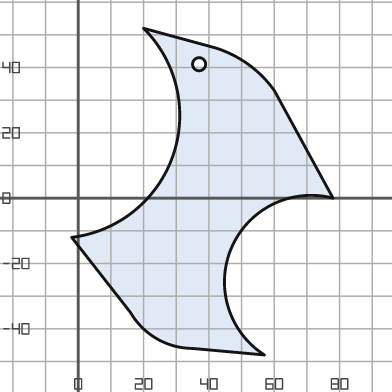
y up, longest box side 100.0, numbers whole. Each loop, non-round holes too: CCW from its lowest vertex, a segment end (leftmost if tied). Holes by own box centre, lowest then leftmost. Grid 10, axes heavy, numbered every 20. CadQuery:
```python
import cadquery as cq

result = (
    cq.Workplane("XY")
    .moveTo(57.0, -48.0)
    .threePointArc((47.0, -15.0), (78.0, 0.0))
    .lineTo(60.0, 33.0)
    .threePointArc((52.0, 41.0), (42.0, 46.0))
    .lineTo(20.0, 52.0)
    .threePointArc((29.0, 13.0), (-2.0, -12.0))
    .lineTo(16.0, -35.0)
    .threePointArc((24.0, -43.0), (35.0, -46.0))
    .close()
    .moveTo(37.0, 41.0)
    .circle(2.0)
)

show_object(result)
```